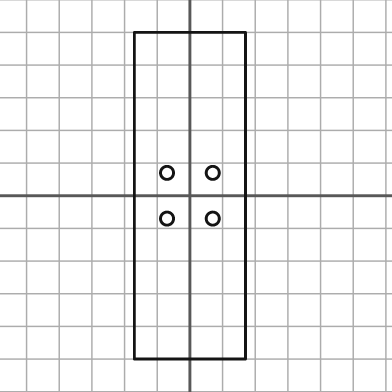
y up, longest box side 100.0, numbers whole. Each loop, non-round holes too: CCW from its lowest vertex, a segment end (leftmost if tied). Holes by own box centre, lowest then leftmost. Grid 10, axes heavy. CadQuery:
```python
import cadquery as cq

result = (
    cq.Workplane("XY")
    .moveTo(-17.0, -50.0)
    .lineTo(17.0, -50.0)
    .lineTo(17.0, 50.0)
    .lineTo(-17.0, 50.0)
    .close()
    .moveTo(-7.0, -7.0)
    .circle(2.0)
    .moveTo(7.0, -7.0)
    .circle(2.0)
    .moveTo(-7.0, 7.0)
    .circle(2.0)
    .moveTo(7.0, 7.0)
    .circle(2.0)
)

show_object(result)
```